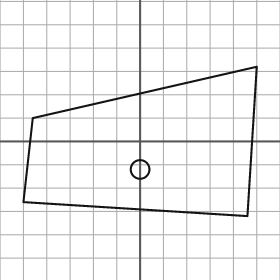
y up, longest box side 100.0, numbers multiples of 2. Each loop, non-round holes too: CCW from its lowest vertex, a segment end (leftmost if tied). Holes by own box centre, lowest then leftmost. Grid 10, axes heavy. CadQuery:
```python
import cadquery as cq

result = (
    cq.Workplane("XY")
    .moveTo(46.0, -32.0)
    .lineTo(50.0, 32.0)
    .lineTo(-46.0, 10.0)
    .lineTo(-50.0, -26.0)
    .close()
    .moveTo(0.0, -12.0)
    .circle(4.0)
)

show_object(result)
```